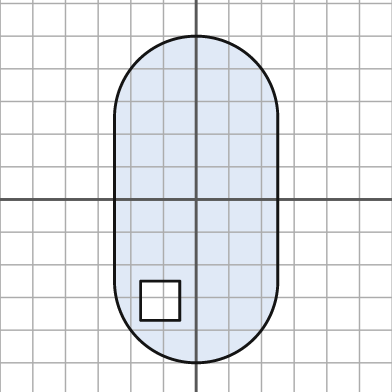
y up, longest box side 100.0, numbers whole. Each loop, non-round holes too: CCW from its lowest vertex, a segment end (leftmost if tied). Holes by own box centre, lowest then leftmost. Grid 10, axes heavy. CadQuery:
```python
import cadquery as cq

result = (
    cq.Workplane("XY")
    .moveTo(-25.0, -25.0)
    .threePointArc((0.0, -50.0), (25.0, -25.0))
    .lineTo(25.0, 25.0)
    .threePointArc((0.0, 50.0), (-25.0, 25.0))
    .close()
    .moveTo(-17.0, -37.0)
    .lineTo(-5.0, -37.0)
    .lineTo(-5.0, -25.0)
    .lineTo(-17.0, -25.0)
    .close()
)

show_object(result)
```